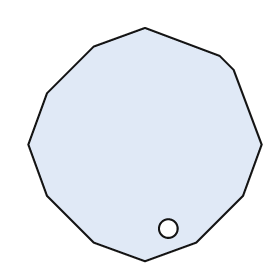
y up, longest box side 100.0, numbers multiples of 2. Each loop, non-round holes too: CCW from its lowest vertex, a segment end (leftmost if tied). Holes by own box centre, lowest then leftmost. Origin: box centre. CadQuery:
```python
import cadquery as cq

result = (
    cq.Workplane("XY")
    .moveTo(0.0, -50.0)
    .lineTo(22.0, -42.0)
    .lineTo(42.0, -22.0)
    .lineTo(50.0, 0.0)
    .lineTo(38.0, 32.0)
    .lineTo(32.0, 38.0)
    .lineTo(0.0, 50.0)
    .lineTo(-22.0, 42.0)
    .lineTo(-42.0, 22.0)
    .lineTo(-50.0, 0.0)
    .lineTo(-42.0, -22.0)
    .lineTo(-22.0, -42.0)
    .close()
    .moveTo(10.0, -36.0)
    .circle(4.0)
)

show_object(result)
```